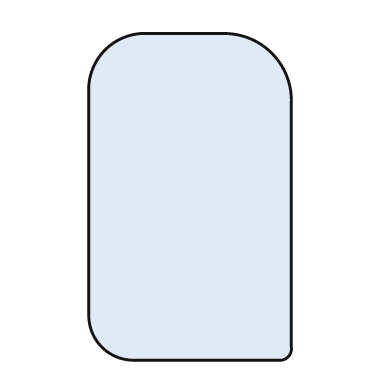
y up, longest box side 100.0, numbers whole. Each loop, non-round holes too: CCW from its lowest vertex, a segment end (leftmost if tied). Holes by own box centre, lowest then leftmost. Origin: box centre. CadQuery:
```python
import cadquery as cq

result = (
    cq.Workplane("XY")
    .moveTo(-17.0, -50.0)
    .lineTo(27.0, -50.0)
    .threePointArc((30.0, -49.0), (31.0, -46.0))
    .lineTo(31.0, 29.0)
    .threePointArc((25.0, 44.0), (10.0, 50.0))
    .lineTo(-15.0, 50.0)
    .threePointArc((-26.0, 45.0), (-31.0, 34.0))
    .lineTo(-31.0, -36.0)
    .threePointArc((-27.0, -46.0), (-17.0, -50.0))
    .close()
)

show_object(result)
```